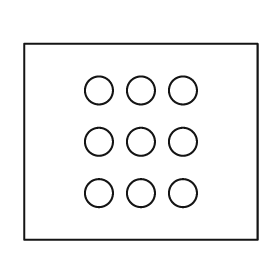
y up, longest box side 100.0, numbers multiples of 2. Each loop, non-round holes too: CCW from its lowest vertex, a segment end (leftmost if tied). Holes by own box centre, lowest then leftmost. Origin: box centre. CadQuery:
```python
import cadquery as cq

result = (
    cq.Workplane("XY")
    .moveTo(-50.0, -42.0)
    .lineTo(50.0, -42.0)
    .lineTo(50.0, 42.0)
    .lineTo(-50.0, 42.0)
    .close()
    .moveTo(-18.0, -22.0)
    .circle(6.0)
    .moveTo(0.0, -22.0)
    .circle(6.0)
    .moveTo(18.0, -22.0)
    .circle(6.0)
    .moveTo(-18.0, 0.0)
    .circle(6.0)
    .moveTo(0.0, 0.0)
    .circle(6.0)
    .moveTo(18.0, 0.0)
    .circle(6.0)
    .moveTo(-18.0, 22.0)
    .circle(6.0)
    .moveTo(0.0, 22.0)
    .circle(6.0)
    .moveTo(18.0, 22.0)
    .circle(6.0)
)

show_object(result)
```